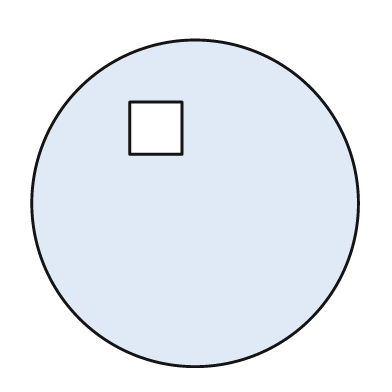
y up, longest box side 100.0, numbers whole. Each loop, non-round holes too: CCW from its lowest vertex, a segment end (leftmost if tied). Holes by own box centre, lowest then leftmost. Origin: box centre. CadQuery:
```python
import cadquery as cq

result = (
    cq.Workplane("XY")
    .moveTo(0.0, 0.0)
    .circle(50.0)
    .moveTo(-20.0, 15.0)
    .lineTo(-4.0, 15.0)
    .lineTo(-4.0, 31.0)
    .lineTo(-20.0, 31.0)
    .close()
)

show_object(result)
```